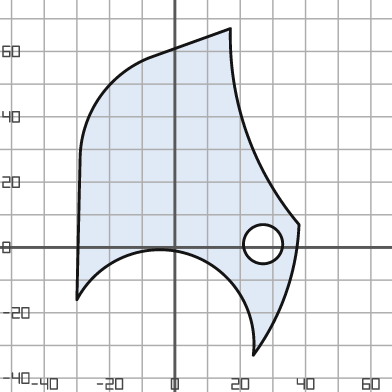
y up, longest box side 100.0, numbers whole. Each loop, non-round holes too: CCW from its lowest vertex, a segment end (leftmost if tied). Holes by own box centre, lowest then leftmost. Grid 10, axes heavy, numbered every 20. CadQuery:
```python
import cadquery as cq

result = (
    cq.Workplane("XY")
    .moveTo(24.0, -33.0)
    .threePointArc((34.0, -14.0), (38.0, 7.0))
    .threePointArc((22.0, 35.0), (17.0, 67.0))
    .lineTo(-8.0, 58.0)
    .threePointArc((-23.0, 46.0), (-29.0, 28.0))
    .lineTo(-30.0, -16.0)
    .threePointArc((4.0, -2.0), (24.0, -33.0))
    .close()
    .moveTo(27.0, 1.0)
    .circle(6.0)
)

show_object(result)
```